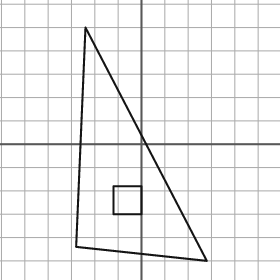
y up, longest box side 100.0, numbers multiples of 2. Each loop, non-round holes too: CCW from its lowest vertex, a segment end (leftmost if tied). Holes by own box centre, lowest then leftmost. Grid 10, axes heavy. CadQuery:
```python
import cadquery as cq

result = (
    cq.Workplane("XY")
    .moveTo(28.0, -50.0)
    .lineTo(-24.0, 50.0)
    .lineTo(-28.0, -44.0)
    .close()
    .moveTo(-12.0, -30.0)
    .lineTo(0.0, -30.0)
    .lineTo(0.0, -18.0)
    .lineTo(-12.0, -18.0)
    .close()
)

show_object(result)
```